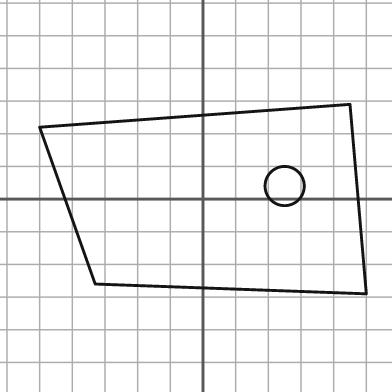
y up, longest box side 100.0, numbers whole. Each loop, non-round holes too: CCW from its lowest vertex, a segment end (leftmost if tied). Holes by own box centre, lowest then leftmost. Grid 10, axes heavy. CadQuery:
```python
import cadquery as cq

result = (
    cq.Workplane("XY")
    .moveTo(50.0, -29.0)
    .lineTo(45.0, 29.0)
    .lineTo(-50.0, 22.0)
    .lineTo(-33.0, -26.0)
    .close()
    .moveTo(25.0, 4.0)
    .circle(6.0)
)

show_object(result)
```